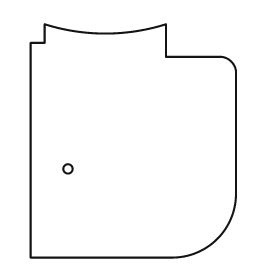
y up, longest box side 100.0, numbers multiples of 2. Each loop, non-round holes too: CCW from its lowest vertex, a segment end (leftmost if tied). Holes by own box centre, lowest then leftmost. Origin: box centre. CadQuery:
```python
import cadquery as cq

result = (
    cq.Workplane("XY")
    .moveTo(-44.0, -50.0)
    .lineTo(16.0, -50.0)
    .threePointArc((36.0, -42.0), (44.0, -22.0))
    .lineTo(44.0, 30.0)
    .threePointArc((42.0, 34.0), (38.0, 36.0))
    .lineTo(14.0, 36.0)
    .lineTo(14.0, 50.0)
    .threePointArc((-12.0, 46.0), (-38.0, 50.0))
    .lineTo(-38.0, 42.0)
    .lineTo(-44.0, 42.0)
    .close()
    .moveTo(-28.0, -12.0)
    .circle(2.0)
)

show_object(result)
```